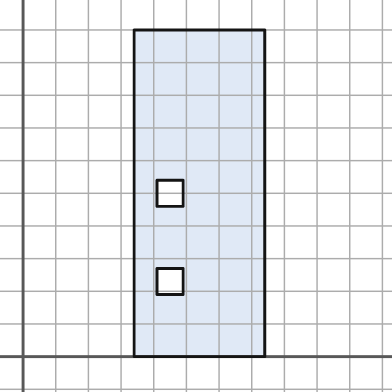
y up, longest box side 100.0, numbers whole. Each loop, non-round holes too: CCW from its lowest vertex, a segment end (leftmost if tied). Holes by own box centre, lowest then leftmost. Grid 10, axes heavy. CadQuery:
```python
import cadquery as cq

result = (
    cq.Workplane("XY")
    .moveTo(34.0, 0.0)
    .lineTo(74.0, 0.0)
    .lineTo(74.0, 100.0)
    .lineTo(34.0, 100.0)
    .close()
    .moveTo(41.0, 19.0)
    .lineTo(49.0, 19.0)
    .lineTo(49.0, 27.0)
    .lineTo(41.0, 27.0)
    .close()
    .moveTo(41.0, 46.0)
    .lineTo(49.0, 46.0)
    .lineTo(49.0, 54.0)
    .lineTo(41.0, 54.0)
    .close()
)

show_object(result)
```